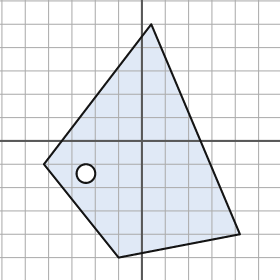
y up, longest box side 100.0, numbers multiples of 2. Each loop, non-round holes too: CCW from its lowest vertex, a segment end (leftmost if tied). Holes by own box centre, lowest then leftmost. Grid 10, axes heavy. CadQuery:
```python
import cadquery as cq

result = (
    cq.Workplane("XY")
    .moveTo(-10.0, -50.0)
    .lineTo(42.0, -40.0)
    .lineTo(4.0, 50.0)
    .lineTo(-42.0, -10.0)
    .close()
    .moveTo(-24.0, -14.0)
    .circle(4.0)
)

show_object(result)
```